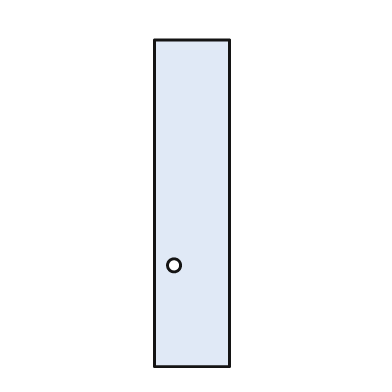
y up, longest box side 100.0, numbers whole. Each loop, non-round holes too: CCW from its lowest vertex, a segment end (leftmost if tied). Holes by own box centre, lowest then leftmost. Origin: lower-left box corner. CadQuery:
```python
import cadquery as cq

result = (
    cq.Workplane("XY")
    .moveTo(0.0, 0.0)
    .lineTo(23.0, 0.0)
    .lineTo(23.0, 100.0)
    .lineTo(0.0, 100.0)
    .close()
    .moveTo(6.0, 31.0)
    .circle(2.0)
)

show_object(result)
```